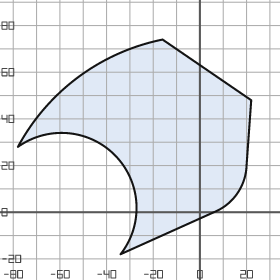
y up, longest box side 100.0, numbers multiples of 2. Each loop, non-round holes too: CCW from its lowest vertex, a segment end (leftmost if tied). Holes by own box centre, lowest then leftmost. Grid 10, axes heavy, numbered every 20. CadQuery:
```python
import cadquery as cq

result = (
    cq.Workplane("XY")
    .moveTo(-34.0, -18.0)
    .lineTo(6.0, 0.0)
    .threePointArc((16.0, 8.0), (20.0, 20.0))
    .lineTo(22.0, 48.0)
    .lineTo(-16.0, 74.0)
    .threePointArc((-52.0, 58.0), (-78.0, 28.0))
    .threePointArc((-36.0, 24.0), (-34.0, -18.0))
    .close()
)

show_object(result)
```